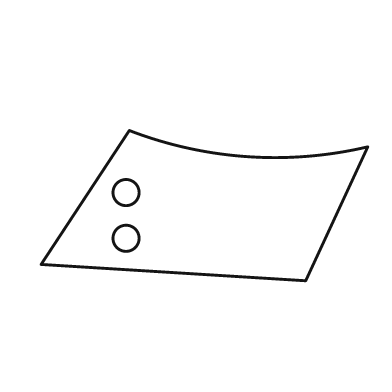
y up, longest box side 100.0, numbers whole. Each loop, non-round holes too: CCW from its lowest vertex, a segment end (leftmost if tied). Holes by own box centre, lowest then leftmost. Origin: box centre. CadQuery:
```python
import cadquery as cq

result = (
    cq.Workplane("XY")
    .moveTo(31.0, -23.0)
    .lineTo(50.0, 18.0)
    .threePointArc((13.0, 15.0), (-23.0, 23.0))
    .lineTo(-50.0, -18.0)
    .close()
    .moveTo(-24.0, -10.0)
    .circle(4.0)
    .moveTo(-24.0, 4.0)
    .circle(4.0)
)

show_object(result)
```